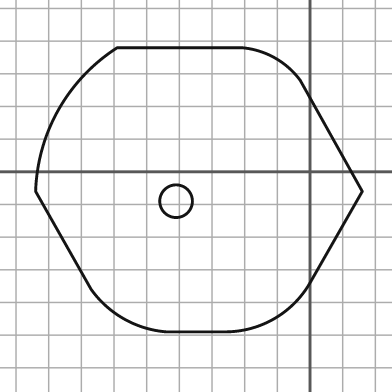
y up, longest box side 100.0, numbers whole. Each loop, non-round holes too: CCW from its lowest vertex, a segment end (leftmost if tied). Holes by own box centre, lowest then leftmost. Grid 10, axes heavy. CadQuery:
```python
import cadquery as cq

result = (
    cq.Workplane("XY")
    .moveTo(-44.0, -49.0)
    .lineTo(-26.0, -49.0)
    .threePointArc((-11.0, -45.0), (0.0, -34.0))
    .lineTo(16.0, -6.0)
    .lineTo(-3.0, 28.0)
    .threePointArc((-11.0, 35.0), (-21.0, 38.0))
    .lineTo(-59.0, 38.0)
    .threePointArc((-77.0, 19.0), (-84.0, -6.0))
    .lineTo(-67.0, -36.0)
    .threePointArc((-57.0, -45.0), (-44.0, -49.0))
    .close()
    .moveTo(-41.0, -9.0)
    .circle(5.0)
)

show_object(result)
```